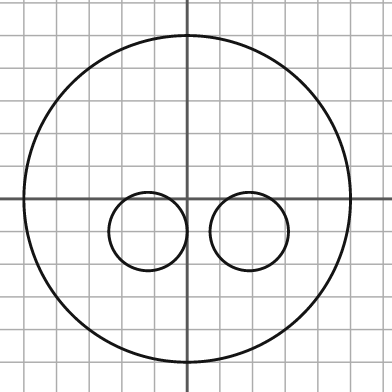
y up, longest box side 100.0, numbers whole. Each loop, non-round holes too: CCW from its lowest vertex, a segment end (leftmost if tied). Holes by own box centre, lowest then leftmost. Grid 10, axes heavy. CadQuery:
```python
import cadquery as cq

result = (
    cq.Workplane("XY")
    .moveTo(0.0, 0.0)
    .circle(50.0)
    .moveTo(-12.0, -10.0)
    .circle(12.0)
    .moveTo(19.0, -10.0)
    .circle(12.0)
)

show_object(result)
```